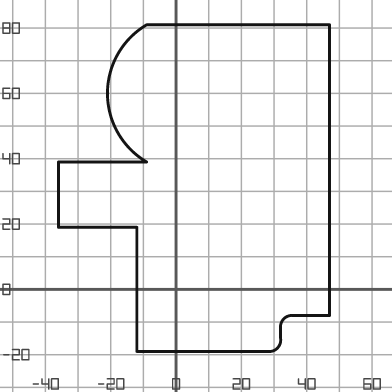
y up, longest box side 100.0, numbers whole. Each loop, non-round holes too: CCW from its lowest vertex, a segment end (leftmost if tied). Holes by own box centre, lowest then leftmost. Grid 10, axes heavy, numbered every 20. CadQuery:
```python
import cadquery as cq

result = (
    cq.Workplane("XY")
    .moveTo(-12.0, -19.0)
    .lineTo(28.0, -19.0)
    .threePointArc((31.0, -18.0), (32.0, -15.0))
    .lineTo(32.0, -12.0)
    .threePointArc((33.0, -9.0), (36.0, -8.0))
    .lineTo(47.0, -8.0)
    .lineTo(47.0, 81.0)
    .lineTo(-9.0, 81.0)
    .threePointArc((-21.0, 60.0), (-9.0, 39.0))
    .lineTo(-36.0, 39.0)
    .lineTo(-36.0, 19.0)
    .lineTo(-12.0, 19.0)
    .close()
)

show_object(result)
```